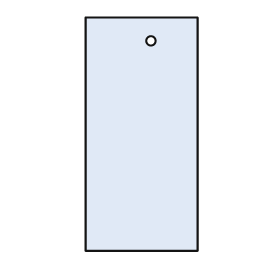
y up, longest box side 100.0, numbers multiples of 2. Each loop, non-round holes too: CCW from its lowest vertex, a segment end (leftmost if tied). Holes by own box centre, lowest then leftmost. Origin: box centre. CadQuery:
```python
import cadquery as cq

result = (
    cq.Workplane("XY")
    .moveTo(-24.0, -50.0)
    .lineTo(24.0, -50.0)
    .lineTo(24.0, 50.0)
    .lineTo(-24.0, 50.0)
    .close()
    .moveTo(4.0, 40.0)
    .circle(2.0)
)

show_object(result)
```